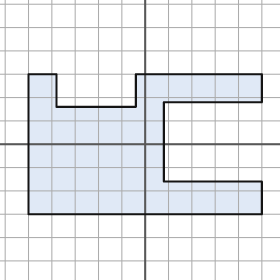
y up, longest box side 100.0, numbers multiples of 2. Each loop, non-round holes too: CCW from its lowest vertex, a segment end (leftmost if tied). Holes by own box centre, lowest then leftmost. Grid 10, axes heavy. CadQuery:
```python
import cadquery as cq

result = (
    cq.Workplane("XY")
    .moveTo(-50.0, -30.0)
    .lineTo(50.0, -30.0)
    .lineTo(50.0, -16.0)
    .lineTo(8.0, -16.0)
    .lineTo(8.0, 18.0)
    .lineTo(50.0, 18.0)
    .lineTo(50.0, 30.0)
    .lineTo(-4.0, 30.0)
    .lineTo(-4.0, 16.0)
    .lineTo(-38.0, 16.0)
    .lineTo(-38.0, 30.0)
    .lineTo(-50.0, 30.0)
    .close()
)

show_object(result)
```